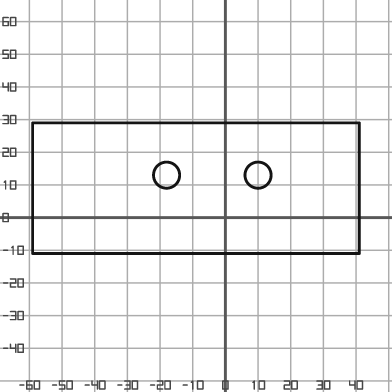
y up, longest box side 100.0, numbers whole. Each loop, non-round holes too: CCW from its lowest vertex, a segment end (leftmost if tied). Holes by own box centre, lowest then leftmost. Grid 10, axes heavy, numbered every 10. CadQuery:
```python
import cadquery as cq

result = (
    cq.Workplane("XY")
    .moveTo(-59.0, -11.0)
    .lineTo(41.0, -11.0)
    .lineTo(41.0, 29.0)
    .lineTo(-59.0, 29.0)
    .close()
    .moveTo(-18.0, 13.0)
    .circle(4.0)
    .moveTo(10.0, 13.0)
    .circle(4.0)
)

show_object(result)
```